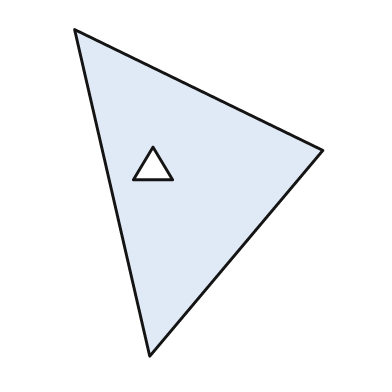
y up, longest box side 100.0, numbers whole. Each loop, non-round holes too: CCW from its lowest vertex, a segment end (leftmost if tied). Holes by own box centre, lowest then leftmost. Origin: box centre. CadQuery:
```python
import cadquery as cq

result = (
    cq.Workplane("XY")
    .moveTo(-15.0, -50.0)
    .lineTo(38.0, 13.0)
    .lineTo(-38.0, 50.0)
    .close()
    .moveTo(-20.0, 4.0)
    .lineTo(-8.0, 4.0)
    .lineTo(-14.0, 14.0)
    .close()
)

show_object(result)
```